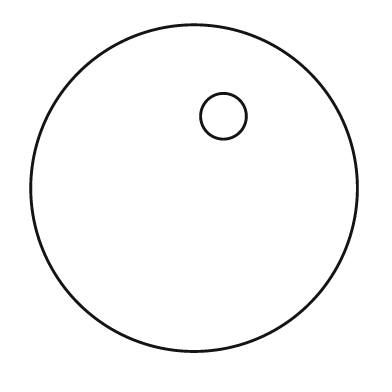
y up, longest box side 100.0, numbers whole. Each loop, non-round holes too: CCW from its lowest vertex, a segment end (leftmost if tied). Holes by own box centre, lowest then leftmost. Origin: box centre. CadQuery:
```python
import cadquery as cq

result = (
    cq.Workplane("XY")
    .moveTo(0.0, 0.0)
    .circle(50.0)
    .moveTo(9.0, 22.0)
    .circle(7.0)
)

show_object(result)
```